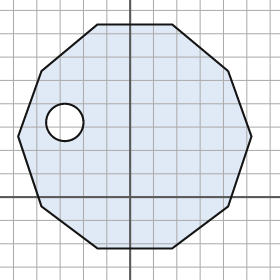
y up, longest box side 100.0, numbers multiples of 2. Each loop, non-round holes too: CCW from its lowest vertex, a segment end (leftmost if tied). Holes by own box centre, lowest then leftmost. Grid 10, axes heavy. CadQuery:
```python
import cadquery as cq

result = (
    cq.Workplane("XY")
    .moveTo(-14.0, -22.0)
    .lineTo(18.0, -22.0)
    .lineTo(42.0, -4.0)
    .lineTo(52.0, 26.0)
    .lineTo(42.0, 54.0)
    .lineTo(18.0, 74.0)
    .lineTo(-14.0, 74.0)
    .lineTo(-38.0, 54.0)
    .lineTo(-48.0, 26.0)
    .lineTo(-38.0, -4.0)
    .close()
    .moveTo(-28.0, 32.0)
    .circle(8.0)
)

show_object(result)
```